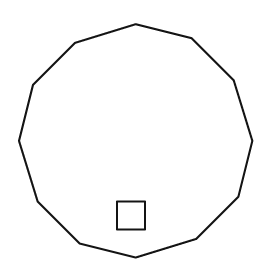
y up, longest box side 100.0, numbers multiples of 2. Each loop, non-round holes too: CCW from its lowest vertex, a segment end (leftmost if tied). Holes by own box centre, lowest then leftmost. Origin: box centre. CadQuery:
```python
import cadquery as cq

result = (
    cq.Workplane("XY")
    .moveTo(0.0, -50.0)
    .lineTo(26.0, -42.0)
    .lineTo(44.0, -24.0)
    .lineTo(50.0, 0.0)
    .lineTo(42.0, 26.0)
    .lineTo(24.0, 44.0)
    .lineTo(0.0, 50.0)
    .lineTo(-26.0, 42.0)
    .lineTo(-44.0, 24.0)
    .lineTo(-50.0, 0.0)
    .lineTo(-42.0, -26.0)
    .lineTo(-24.0, -44.0)
    .close()
    .moveTo(-8.0, -38.0)
    .lineTo(4.0, -38.0)
    .lineTo(4.0, -26.0)
    .lineTo(-8.0, -26.0)
    .close()
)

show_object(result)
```